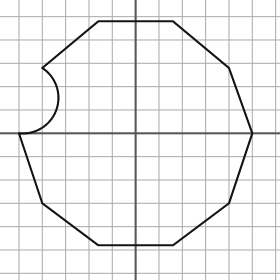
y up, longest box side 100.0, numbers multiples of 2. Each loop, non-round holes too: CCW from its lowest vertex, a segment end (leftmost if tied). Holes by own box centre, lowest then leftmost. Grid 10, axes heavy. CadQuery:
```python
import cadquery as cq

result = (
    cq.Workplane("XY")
    .moveTo(-16.0, -48.0)
    .lineTo(16.0, -48.0)
    .lineTo(40.0, -30.0)
    .lineTo(50.0, 0.0)
    .lineTo(40.0, 28.0)
    .lineTo(16.0, 48.0)
    .lineTo(-16.0, 48.0)
    .lineTo(-40.0, 28.0)
    .threePointArc((-34.0, 10.0), (-50.0, 0.0))
    .lineTo(-40.0, -30.0)
    .close()
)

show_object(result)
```